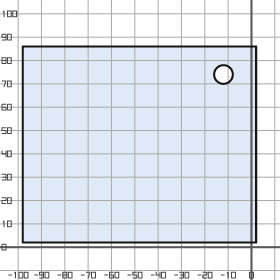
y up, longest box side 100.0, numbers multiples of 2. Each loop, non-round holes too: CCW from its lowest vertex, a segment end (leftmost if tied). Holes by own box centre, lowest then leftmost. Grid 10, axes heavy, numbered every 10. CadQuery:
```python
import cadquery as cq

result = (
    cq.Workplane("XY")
    .moveTo(-98.0, 2.0)
    .lineTo(2.0, 2.0)
    .lineTo(2.0, 86.0)
    .lineTo(-98.0, 86.0)
    .close()
    .moveTo(-12.0, 74.0)
    .circle(4.0)
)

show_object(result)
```